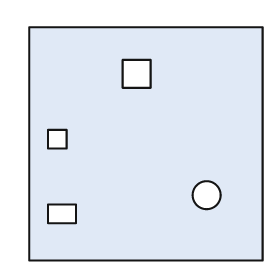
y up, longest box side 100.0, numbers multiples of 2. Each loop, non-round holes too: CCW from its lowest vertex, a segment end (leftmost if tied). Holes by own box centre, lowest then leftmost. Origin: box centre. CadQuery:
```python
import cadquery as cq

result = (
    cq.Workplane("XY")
    .moveTo(-50.0, -50.0)
    .lineTo(50.0, -50.0)
    .lineTo(50.0, 50.0)
    .lineTo(-50.0, 50.0)
    .close()
    .moveTo(-42.0, -34.0)
    .lineTo(-30.0, -34.0)
    .lineTo(-30.0, -26.0)
    .lineTo(-42.0, -26.0)
    .close()
    .moveTo(26.0, -22.0)
    .circle(6.0)
    .moveTo(-42.0, -2.0)
    .lineTo(-34.0, -2.0)
    .lineTo(-34.0, 6.0)
    .lineTo(-42.0, 6.0)
    .close()
    .moveTo(-10.0, 24.0)
    .lineTo(2.0, 24.0)
    .lineTo(2.0, 36.0)
    .lineTo(-10.0, 36.0)
    .close()
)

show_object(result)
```